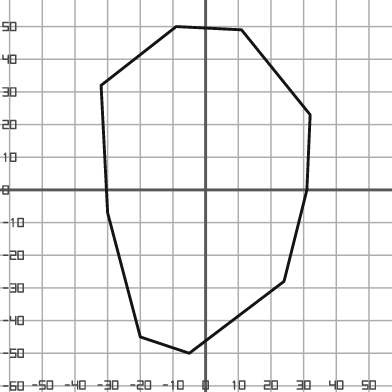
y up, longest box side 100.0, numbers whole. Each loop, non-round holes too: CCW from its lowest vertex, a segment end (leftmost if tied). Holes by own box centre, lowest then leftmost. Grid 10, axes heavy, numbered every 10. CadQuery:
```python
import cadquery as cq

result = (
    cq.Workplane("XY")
    .moveTo(-5.0, -50.0)
    .lineTo(24.0, -28.0)
    .lineTo(31.0, 0.0)
    .lineTo(32.0, 23.0)
    .lineTo(11.0, 49.0)
    .lineTo(-9.0, 50.0)
    .lineTo(-32.0, 32.0)
    .lineTo(-30.0, -7.0)
    .lineTo(-20.0, -45.0)
    .close()
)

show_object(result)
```